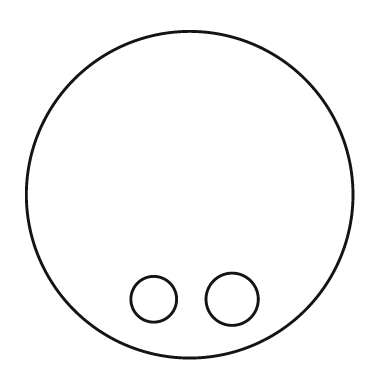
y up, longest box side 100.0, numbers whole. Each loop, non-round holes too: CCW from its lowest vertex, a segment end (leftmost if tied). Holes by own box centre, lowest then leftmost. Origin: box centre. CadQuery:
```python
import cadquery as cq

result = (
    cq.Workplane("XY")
    .moveTo(0.0, 0.0)
    .circle(50.0)
    .moveTo(-11.0, -32.0)
    .circle(7.0)
    .moveTo(13.0, -32.0)
    .circle(8.0)
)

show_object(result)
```